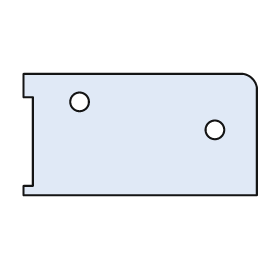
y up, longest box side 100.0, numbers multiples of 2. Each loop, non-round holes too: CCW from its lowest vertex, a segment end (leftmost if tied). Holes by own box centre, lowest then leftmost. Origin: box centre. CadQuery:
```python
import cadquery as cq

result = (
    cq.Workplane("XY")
    .moveTo(-50.0, -26.0)
    .lineTo(50.0, -26.0)
    .lineTo(50.0, 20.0)
    .threePointArc((48.0, 24.0), (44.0, 26.0))
    .lineTo(-50.0, 26.0)
    .lineTo(-50.0, 16.0)
    .lineTo(-46.0, 16.0)
    .lineTo(-46.0, -22.0)
    .lineTo(-50.0, -22.0)
    .close()
    .moveTo(32.0, 2.0)
    .circle(4.0)
    .moveTo(-26.0, 14.0)
    .circle(4.0)
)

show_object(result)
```